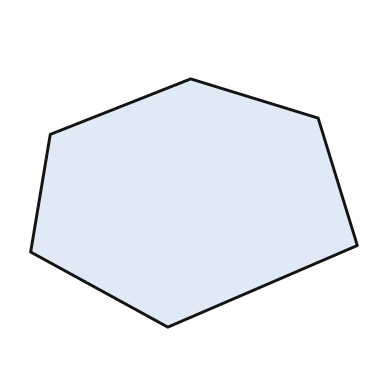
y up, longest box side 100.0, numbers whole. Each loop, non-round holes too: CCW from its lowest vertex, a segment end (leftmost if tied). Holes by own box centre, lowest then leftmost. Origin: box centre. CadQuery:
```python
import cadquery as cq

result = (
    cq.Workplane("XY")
    .moveTo(-8.0, -38.0)
    .lineTo(50.0, -13.0)
    .lineTo(38.0, 26.0)
    .lineTo(-1.0, 38.0)
    .lineTo(-44.0, 21.0)
    .lineTo(-50.0, -15.0)
    .close()
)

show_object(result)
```